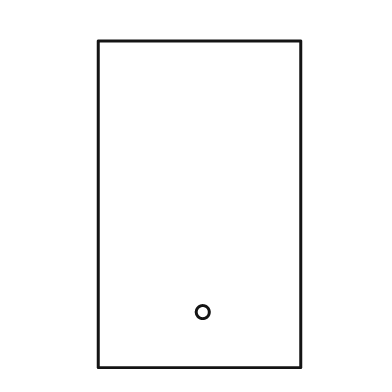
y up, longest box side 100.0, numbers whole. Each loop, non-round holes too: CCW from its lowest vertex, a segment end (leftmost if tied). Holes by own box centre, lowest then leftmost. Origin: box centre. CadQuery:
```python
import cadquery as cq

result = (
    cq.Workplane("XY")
    .moveTo(-31.0, -50.0)
    .lineTo(31.0, -50.0)
    .lineTo(31.0, 50.0)
    .lineTo(-31.0, 50.0)
    .close()
    .moveTo(1.0, -33.0)
    .circle(2.0)
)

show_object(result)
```